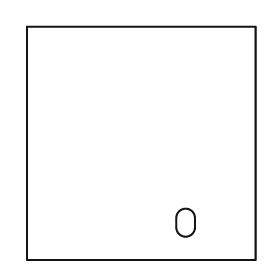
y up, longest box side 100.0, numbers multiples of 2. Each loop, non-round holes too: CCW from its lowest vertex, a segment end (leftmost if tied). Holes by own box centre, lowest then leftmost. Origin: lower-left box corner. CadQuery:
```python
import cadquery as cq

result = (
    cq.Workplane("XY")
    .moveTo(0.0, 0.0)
    .lineTo(98.0, 0.0)
    .lineTo(98.0, 100.0)
    .lineTo(0.0, 100.0)
    .close()
    .moveTo(64.0, 14.0)
    .threePointArc((68.0, 10.0), (72.0, 14.0))
    .lineTo(72.0, 18.0)
    .threePointArc((68.0, 22.0), (64.0, 18.0))
    .close()
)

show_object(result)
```